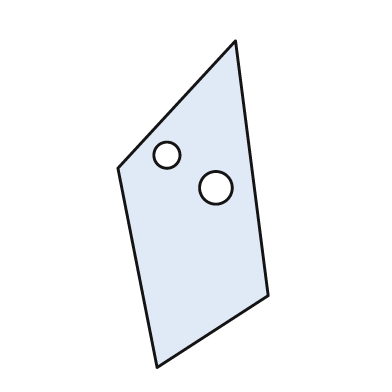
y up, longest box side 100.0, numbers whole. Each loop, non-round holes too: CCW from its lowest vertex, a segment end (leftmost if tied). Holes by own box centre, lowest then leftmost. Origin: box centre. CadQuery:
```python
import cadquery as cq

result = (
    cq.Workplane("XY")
    .moveTo(-11.0, -50.0)
    .lineTo(23.0, -28.0)
    .lineTo(13.0, 50.0)
    .lineTo(-23.0, 11.0)
    .close()
    .moveTo(7.0, 5.0)
    .circle(5.0)
    .moveTo(-8.0, 15.0)
    .circle(4.0)
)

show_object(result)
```